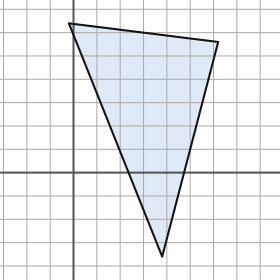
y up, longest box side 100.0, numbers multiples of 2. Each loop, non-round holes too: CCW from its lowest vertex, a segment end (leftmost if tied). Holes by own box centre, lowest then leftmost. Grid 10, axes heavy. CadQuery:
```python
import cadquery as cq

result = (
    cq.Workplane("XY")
    .moveTo(38.0, -36.0)
    .lineTo(62.0, 56.0)
    .lineTo(-2.0, 64.0)
    .close()
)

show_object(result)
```